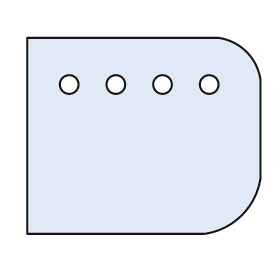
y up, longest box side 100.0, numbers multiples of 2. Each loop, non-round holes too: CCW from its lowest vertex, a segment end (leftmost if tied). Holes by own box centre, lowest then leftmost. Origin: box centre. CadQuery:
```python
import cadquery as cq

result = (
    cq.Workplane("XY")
    .moveTo(-50.0, -42.0)
    .lineTo(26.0, -42.0)
    .threePointArc((42.0, -34.0), (50.0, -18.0))
    .lineTo(50.0, 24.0)
    .threePointArc((44.0, 36.0), (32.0, 42.0))
    .lineTo(-50.0, 42.0)
    .close()
    .moveTo(-32.0, 22.0)
    .circle(4.0)
    .moveTo(-12.0, 22.0)
    .circle(4.0)
    .moveTo(8.0, 22.0)
    .circle(4.0)
    .moveTo(28.0, 22.0)
    .circle(4.0)
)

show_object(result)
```